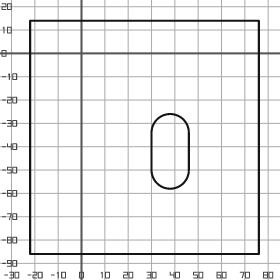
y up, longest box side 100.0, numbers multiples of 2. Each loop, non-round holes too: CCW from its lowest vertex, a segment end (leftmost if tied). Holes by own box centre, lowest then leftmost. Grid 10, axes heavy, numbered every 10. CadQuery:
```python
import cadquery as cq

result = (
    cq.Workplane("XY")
    .moveTo(-22.0, -86.0)
    .lineTo(76.0, -86.0)
    .lineTo(76.0, 14.0)
    .lineTo(-22.0, 14.0)
    .close()
    .moveTo(30.0, -50.0)
    .threePointArc((38.0, -58.0), (46.0, -50.0))
    .lineTo(46.0, -34.0)
    .threePointArc((38.0, -26.0), (30.0, -34.0))
    .close()
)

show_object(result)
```